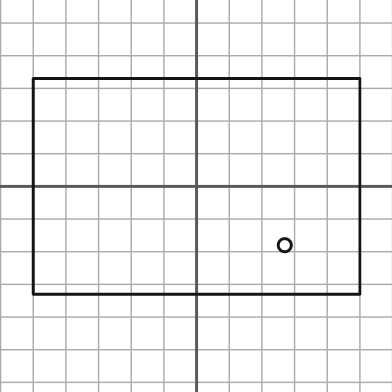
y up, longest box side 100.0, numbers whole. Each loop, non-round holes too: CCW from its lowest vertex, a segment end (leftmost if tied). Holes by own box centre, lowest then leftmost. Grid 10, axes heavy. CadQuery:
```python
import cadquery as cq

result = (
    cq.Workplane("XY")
    .moveTo(-50.0, -33.0)
    .lineTo(50.0, -33.0)
    .lineTo(50.0, 33.0)
    .lineTo(-50.0, 33.0)
    .close()
    .moveTo(27.0, -18.0)
    .circle(2.0)
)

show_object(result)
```